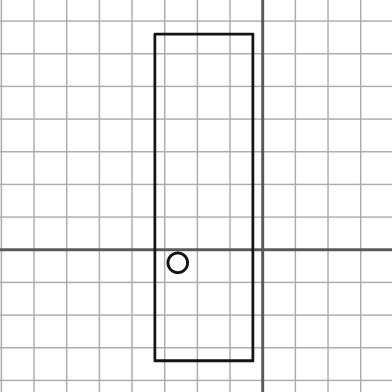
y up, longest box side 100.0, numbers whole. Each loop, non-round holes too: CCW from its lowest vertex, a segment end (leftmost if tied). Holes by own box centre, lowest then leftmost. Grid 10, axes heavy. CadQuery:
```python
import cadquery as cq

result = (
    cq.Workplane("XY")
    .moveTo(-33.0, -34.0)
    .lineTo(-3.0, -34.0)
    .lineTo(-3.0, 66.0)
    .lineTo(-33.0, 66.0)
    .close()
    .moveTo(-26.0, -4.0)
    .circle(3.0)
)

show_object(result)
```